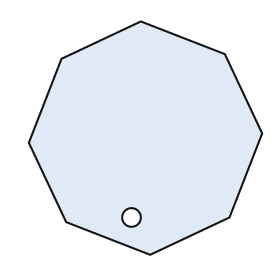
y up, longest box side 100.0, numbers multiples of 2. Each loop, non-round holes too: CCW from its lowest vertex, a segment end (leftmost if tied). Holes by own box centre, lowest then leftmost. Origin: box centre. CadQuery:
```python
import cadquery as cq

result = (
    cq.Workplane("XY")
    .moveTo(2.0, -50.0)
    .lineTo(36.0, -34.0)
    .lineTo(50.0, 2.0)
    .lineTo(34.0, 36.0)
    .lineTo(-2.0, 50.0)
    .lineTo(-36.0, 34.0)
    .lineTo(-50.0, -2.0)
    .lineTo(-34.0, -36.0)
    .close()
    .moveTo(-6.0, -34.0)
    .circle(4.0)
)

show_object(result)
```